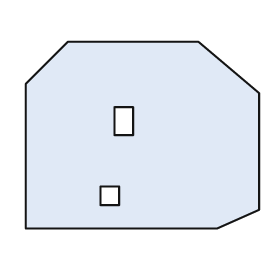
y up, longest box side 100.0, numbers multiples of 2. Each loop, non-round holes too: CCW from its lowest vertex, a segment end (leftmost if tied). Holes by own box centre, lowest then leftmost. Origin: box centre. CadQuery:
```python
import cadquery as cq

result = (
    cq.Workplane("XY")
    .moveTo(-50.0, -40.0)
    .lineTo(32.0, -40.0)
    .lineTo(50.0, -32.0)
    .lineTo(50.0, 18.0)
    .lineTo(24.0, 40.0)
    .lineTo(-32.0, 40.0)
    .lineTo(-50.0, 22.0)
    .close()
    .moveTo(-18.0, -30.0)
    .lineTo(-10.0, -30.0)
    .lineTo(-10.0, -22.0)
    .lineTo(-18.0, -22.0)
    .close()
    .moveTo(-12.0, 0.0)
    .lineTo(-4.0, 0.0)
    .lineTo(-4.0, 12.0)
    .lineTo(-12.0, 12.0)
    .close()
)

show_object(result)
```